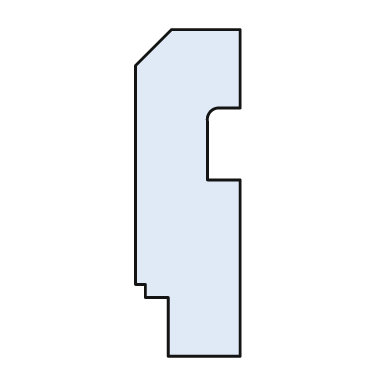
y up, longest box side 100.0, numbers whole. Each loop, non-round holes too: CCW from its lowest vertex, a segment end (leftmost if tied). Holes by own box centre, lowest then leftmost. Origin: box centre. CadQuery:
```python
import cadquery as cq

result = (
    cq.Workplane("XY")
    .moveTo(-6.0, -50.0)
    .lineTo(16.0, -50.0)
    .lineTo(16.0, 4.0)
    .lineTo(6.0, 4.0)
    .lineTo(6.0, 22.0)
    .threePointArc((7.0, 25.0), (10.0, 26.0))
    .lineTo(16.0, 26.0)
    .lineTo(16.0, 50.0)
    .lineTo(-5.0, 50.0)
    .lineTo(-16.0, 39.0)
    .lineTo(-16.0, -28.0)
    .lineTo(-13.0, -28.0)
    .lineTo(-13.0, -32.0)
    .lineTo(-6.0, -32.0)
    .close()
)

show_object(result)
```